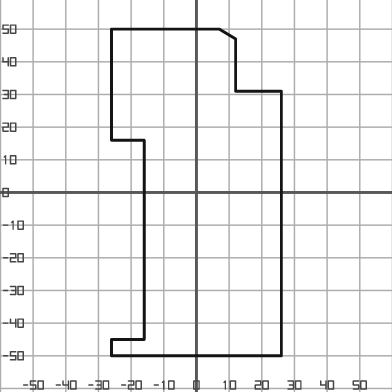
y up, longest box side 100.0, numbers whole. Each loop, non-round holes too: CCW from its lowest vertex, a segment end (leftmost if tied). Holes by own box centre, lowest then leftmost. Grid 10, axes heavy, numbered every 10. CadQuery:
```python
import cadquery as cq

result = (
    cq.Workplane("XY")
    .moveTo(-26.0, -50.0)
    .lineTo(26.0, -50.0)
    .lineTo(26.0, 31.0)
    .lineTo(12.0, 31.0)
    .lineTo(12.0, 47.0)
    .lineTo(7.0, 50.0)
    .lineTo(-26.0, 50.0)
    .lineTo(-26.0, 16.0)
    .lineTo(-16.0, 16.0)
    .lineTo(-16.0, -45.0)
    .lineTo(-26.0, -45.0)
    .close()
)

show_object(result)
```